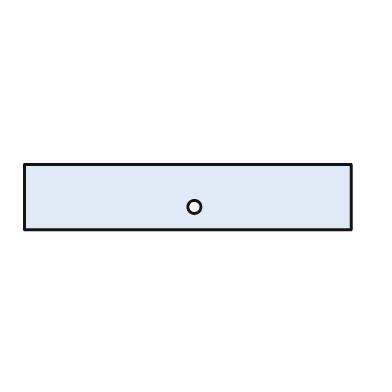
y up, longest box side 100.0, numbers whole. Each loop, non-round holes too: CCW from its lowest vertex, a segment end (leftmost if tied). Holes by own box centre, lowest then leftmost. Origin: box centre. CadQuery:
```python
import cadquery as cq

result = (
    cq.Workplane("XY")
    .moveTo(-50.0, -10.0)
    .lineTo(50.0, -10.0)
    .lineTo(50.0, 10.0)
    .lineTo(-50.0, 10.0)
    .close()
    .moveTo(2.0, -3.0)
    .circle(2.0)
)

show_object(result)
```